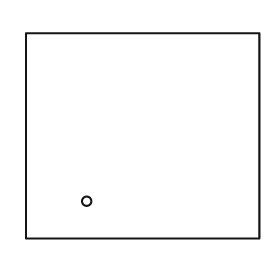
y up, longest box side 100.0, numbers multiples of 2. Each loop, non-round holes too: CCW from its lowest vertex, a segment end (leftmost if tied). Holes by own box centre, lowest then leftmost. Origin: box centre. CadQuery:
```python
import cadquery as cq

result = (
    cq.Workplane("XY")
    .moveTo(-50.0, -44.0)
    .lineTo(50.0, -44.0)
    .lineTo(50.0, 44.0)
    .lineTo(-50.0, 44.0)
    .close()
    .moveTo(-24.0, -28.0)
    .circle(2.0)
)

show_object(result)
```